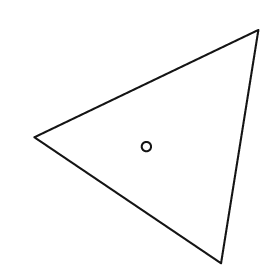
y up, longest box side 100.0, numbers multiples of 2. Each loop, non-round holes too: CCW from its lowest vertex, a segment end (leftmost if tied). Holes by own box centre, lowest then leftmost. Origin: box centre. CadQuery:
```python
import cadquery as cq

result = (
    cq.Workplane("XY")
    .moveTo(32.0, -50.0)
    .lineTo(48.0, 50.0)
    .lineTo(-48.0, 4.0)
    .close()
    .moveTo(0.0, 0.0)
    .circle(2.0)
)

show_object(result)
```